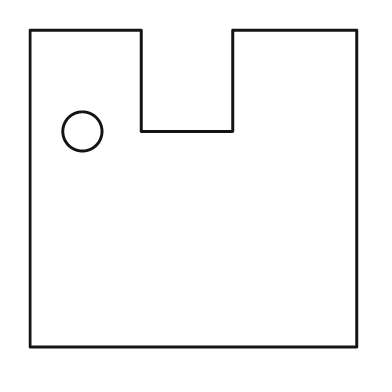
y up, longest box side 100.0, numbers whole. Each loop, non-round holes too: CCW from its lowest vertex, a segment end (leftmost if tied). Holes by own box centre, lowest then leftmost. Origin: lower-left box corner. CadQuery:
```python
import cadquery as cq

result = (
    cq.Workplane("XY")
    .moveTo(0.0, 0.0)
    .lineTo(100.0, 0.0)
    .lineTo(100.0, 97.0)
    .lineTo(62.0, 97.0)
    .lineTo(62.0, 66.0)
    .lineTo(34.0, 66.0)
    .lineTo(34.0, 97.0)
    .lineTo(0.0, 97.0)
    .close()
    .moveTo(16.0, 66.0)
    .circle(6.0)
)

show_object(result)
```